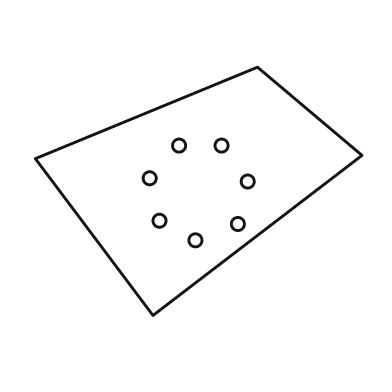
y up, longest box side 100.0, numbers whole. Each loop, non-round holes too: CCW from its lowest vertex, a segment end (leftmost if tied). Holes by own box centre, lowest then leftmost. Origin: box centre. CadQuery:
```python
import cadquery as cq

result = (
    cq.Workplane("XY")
    .moveTo(-14.0, -38.0)
    .lineTo(50.0, 11.0)
    .lineTo(18.0, 38.0)
    .lineTo(-50.0, 10.0)
    .close()
    .moveTo(-1.0, -15.0)
    .circle(2.0)
    .moveTo(12.0, -10.0)
    .circle(2.0)
    .moveTo(-12.0, -9.0)
    .circle(2.0)
    .moveTo(15.0, 3.0)
    .circle(2.0)
    .moveTo(-15.0, 4.0)
    .circle(2.0)
    .moveTo(-6.0, 14.0)
    .circle(2.0)
    .moveTo(7.0, 14.0)
    .circle(2.0)
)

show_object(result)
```